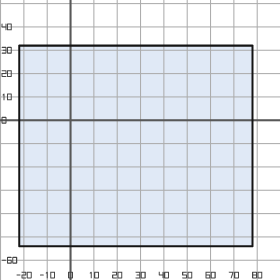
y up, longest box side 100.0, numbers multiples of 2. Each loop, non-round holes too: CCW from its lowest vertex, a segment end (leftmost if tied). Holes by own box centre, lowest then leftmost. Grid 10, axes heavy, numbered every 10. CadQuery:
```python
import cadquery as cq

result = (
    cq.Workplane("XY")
    .moveTo(-22.0, -54.0)
    .lineTo(78.0, -54.0)
    .lineTo(78.0, 32.0)
    .lineTo(-22.0, 32.0)
    .close()
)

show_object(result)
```